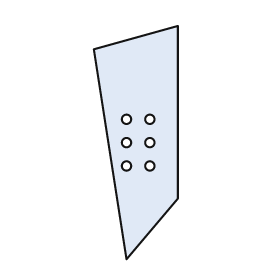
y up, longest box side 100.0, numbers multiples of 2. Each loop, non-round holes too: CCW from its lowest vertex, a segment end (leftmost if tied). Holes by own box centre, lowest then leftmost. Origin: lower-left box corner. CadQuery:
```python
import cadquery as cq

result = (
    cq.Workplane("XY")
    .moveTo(14.0, 0.0)
    .lineTo(36.0, 26.0)
    .lineTo(36.0, 100.0)
    .lineTo(0.0, 90.0)
    .close()
    .moveTo(14.0, 40.0)
    .circle(2.0)
    .moveTo(24.0, 40.0)
    .circle(2.0)
    .moveTo(14.0, 50.0)
    .circle(2.0)
    .moveTo(24.0, 50.0)
    .circle(2.0)
    .moveTo(14.0, 60.0)
    .circle(2.0)
    .moveTo(24.0, 60.0)
    .circle(2.0)
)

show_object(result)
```